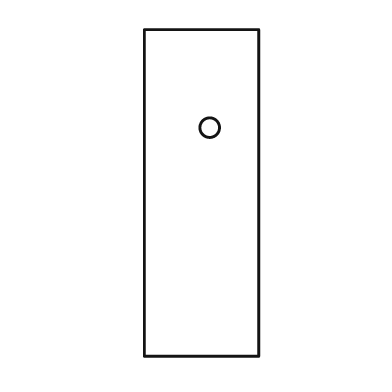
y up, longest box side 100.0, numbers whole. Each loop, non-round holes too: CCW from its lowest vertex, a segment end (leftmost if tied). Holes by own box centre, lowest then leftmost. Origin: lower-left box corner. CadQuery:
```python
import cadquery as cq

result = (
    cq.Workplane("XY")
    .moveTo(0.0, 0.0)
    .lineTo(35.0, 0.0)
    .lineTo(35.0, 100.0)
    .lineTo(0.0, 100.0)
    .close()
    .moveTo(20.0, 70.0)
    .circle(3.0)
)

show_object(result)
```